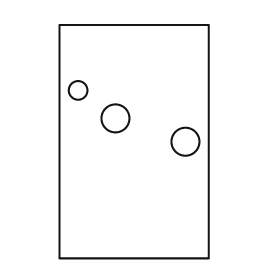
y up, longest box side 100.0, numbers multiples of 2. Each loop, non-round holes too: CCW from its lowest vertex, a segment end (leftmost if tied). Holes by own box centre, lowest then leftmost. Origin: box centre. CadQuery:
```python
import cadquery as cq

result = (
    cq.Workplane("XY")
    .moveTo(-32.0, -50.0)
    .lineTo(32.0, -50.0)
    .lineTo(32.0, 50.0)
    .lineTo(-32.0, 50.0)
    .close()
    .moveTo(22.0, 0.0)
    .circle(6.0)
    .moveTo(-8.0, 10.0)
    .circle(6.0)
    .moveTo(-24.0, 22.0)
    .circle(4.0)
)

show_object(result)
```